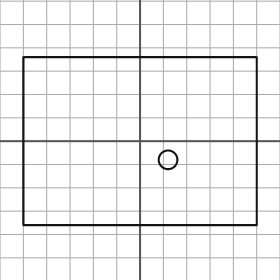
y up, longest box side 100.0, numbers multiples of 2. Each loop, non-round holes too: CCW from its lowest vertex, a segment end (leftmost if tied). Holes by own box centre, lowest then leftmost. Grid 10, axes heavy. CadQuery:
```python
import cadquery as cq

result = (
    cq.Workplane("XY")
    .moveTo(-50.0, -36.0)
    .lineTo(50.0, -36.0)
    .lineTo(50.0, 36.0)
    .lineTo(-50.0, 36.0)
    .close()
    .moveTo(12.0, -8.0)
    .circle(4.0)
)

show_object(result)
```